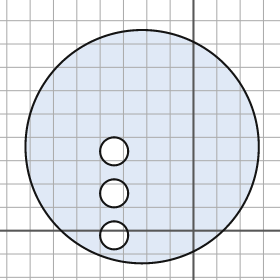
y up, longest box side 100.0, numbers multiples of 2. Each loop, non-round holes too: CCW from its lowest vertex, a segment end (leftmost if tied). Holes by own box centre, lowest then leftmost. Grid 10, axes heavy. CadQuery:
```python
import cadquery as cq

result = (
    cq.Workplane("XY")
    .moveTo(-22.0, 36.0)
    .circle(50.0)
    .moveTo(-34.0, -2.0)
    .circle(6.0)
    .moveTo(-34.0, 16.0)
    .circle(6.0)
    .moveTo(-34.0, 34.0)
    .circle(6.0)
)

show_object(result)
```